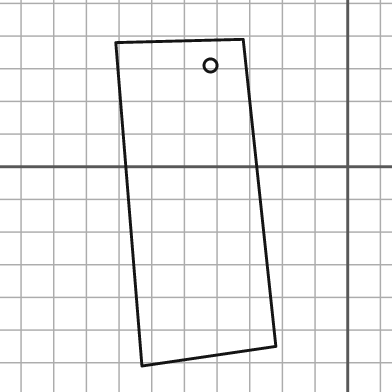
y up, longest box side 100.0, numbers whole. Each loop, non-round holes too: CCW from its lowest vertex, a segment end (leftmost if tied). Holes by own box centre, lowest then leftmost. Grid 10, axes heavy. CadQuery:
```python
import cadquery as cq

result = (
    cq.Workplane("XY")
    .moveTo(-63.0, -61.0)
    .lineTo(-22.0, -55.0)
    .lineTo(-32.0, 39.0)
    .lineTo(-71.0, 38.0)
    .close()
    .moveTo(-42.0, 31.0)
    .circle(2.0)
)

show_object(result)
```